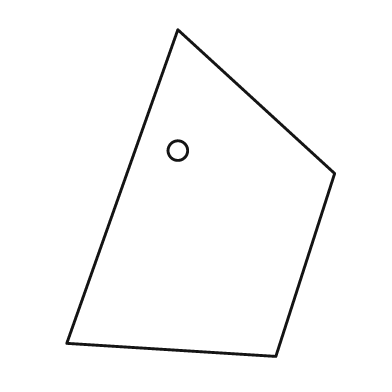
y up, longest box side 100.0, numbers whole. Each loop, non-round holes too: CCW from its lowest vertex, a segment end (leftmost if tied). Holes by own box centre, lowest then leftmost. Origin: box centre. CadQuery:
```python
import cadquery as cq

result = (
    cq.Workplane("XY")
    .moveTo(23.0, -50.0)
    .lineTo(41.0, 6.0)
    .lineTo(-7.0, 50.0)
    .lineTo(-41.0, -46.0)
    .close()
    .moveTo(-7.0, 13.0)
    .circle(3.0)
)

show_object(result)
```